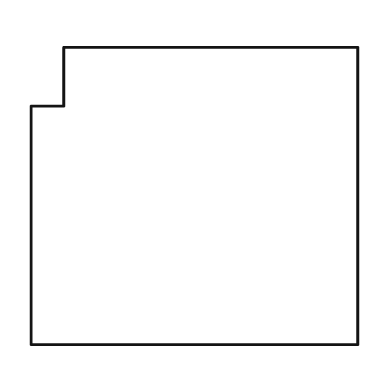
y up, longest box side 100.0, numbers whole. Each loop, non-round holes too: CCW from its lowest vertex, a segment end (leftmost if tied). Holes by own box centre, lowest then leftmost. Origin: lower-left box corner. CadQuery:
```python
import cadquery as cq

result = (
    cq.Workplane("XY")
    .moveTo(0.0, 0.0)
    .lineTo(100.0, 0.0)
    .lineTo(100.0, 91.0)
    .lineTo(10.0, 91.0)
    .lineTo(10.0, 73.0)
    .lineTo(0.0, 73.0)
    .close()
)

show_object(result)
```